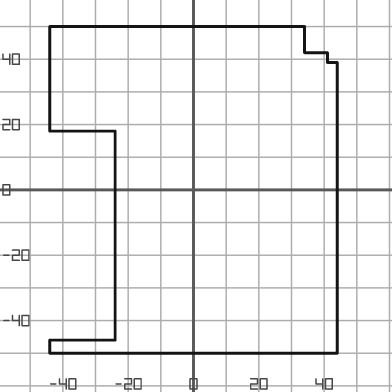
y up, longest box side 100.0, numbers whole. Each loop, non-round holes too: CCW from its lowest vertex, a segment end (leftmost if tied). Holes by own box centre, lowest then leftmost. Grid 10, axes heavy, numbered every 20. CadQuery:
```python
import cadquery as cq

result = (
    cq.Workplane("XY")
    .moveTo(-44.0, -50.0)
    .lineTo(44.0, -50.0)
    .lineTo(44.0, 39.0)
    .lineTo(41.0, 39.0)
    .lineTo(41.0, 42.0)
    .lineTo(34.0, 42.0)
    .lineTo(34.0, 50.0)
    .lineTo(-44.0, 50.0)
    .lineTo(-44.0, 18.0)
    .lineTo(-24.0, 18.0)
    .lineTo(-24.0, -46.0)
    .lineTo(-44.0, -46.0)
    .close()
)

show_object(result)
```